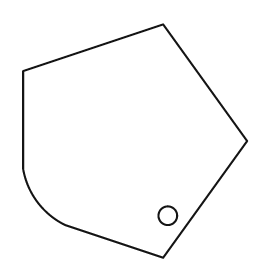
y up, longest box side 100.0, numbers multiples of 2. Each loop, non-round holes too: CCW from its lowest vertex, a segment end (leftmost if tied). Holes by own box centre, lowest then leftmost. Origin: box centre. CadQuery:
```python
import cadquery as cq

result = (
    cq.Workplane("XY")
    .moveTo(12.0, -50.0)
    .lineTo(48.0, 0.0)
    .lineTo(12.0, 50.0)
    .lineTo(-48.0, 30.0)
    .lineTo(-48.0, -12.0)
    .threePointArc((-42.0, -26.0), (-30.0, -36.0))
    .close()
    .moveTo(14.0, -32.0)
    .circle(4.0)
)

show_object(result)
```